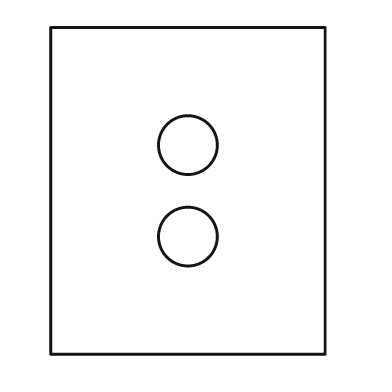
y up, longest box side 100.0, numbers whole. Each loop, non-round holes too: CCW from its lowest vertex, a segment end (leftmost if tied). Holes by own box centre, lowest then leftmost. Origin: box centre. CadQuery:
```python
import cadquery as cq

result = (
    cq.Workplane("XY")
    .moveTo(-42.0, -50.0)
    .lineTo(42.0, -50.0)
    .lineTo(42.0, 50.0)
    .lineTo(-42.0, 50.0)
    .close()
    .moveTo(0.0, -14.0)
    .circle(9.0)
    .moveTo(0.0, 14.0)
    .circle(9.0)
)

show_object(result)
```